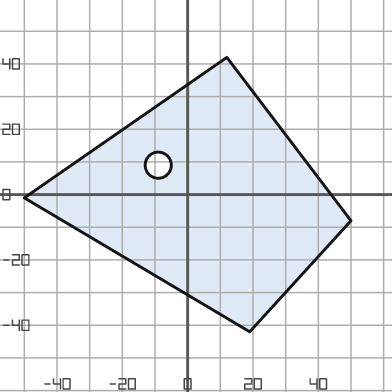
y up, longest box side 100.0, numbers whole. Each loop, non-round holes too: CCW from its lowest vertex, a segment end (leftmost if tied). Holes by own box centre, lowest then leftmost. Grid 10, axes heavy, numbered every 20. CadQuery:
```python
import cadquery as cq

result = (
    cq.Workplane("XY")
    .moveTo(19.0, -42.0)
    .lineTo(50.0, -8.0)
    .lineTo(12.0, 42.0)
    .lineTo(-50.0, -1.0)
    .close()
    .moveTo(-9.0, 9.0)
    .circle(4.0)
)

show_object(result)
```